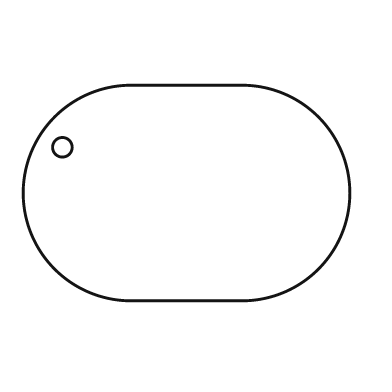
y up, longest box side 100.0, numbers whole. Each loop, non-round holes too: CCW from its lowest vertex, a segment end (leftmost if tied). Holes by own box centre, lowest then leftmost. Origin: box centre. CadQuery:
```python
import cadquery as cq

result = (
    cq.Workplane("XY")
    .moveTo(-17.0, -33.0)
    .lineTo(17.0, -33.0)
    .threePointArc((50.0, 0.0), (17.0, 33.0))
    .lineTo(-17.0, 33.0)
    .threePointArc((-50.0, 0.0), (-17.0, -33.0))
    .close()
    .moveTo(-38.0, 14.0)
    .circle(3.0)
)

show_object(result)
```